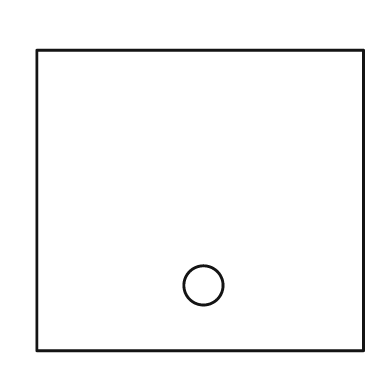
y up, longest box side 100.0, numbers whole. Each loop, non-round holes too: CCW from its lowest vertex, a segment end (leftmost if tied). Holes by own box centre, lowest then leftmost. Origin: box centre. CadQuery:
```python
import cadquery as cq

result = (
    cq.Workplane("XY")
    .moveTo(-50.0, -46.0)
    .lineTo(50.0, -46.0)
    .lineTo(50.0, 46.0)
    .lineTo(-50.0, 46.0)
    .close()
    .moveTo(1.0, -26.0)
    .circle(6.0)
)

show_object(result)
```